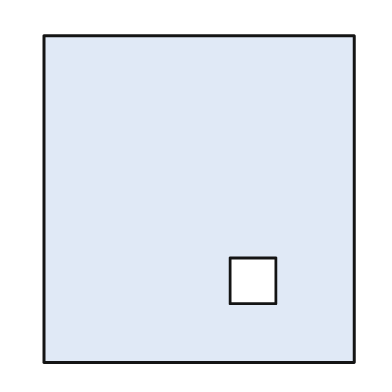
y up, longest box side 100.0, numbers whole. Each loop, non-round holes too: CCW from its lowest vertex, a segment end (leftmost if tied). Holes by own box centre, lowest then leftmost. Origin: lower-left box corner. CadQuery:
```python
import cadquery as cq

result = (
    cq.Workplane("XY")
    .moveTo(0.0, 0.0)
    .lineTo(95.0, 0.0)
    .lineTo(95.0, 100.0)
    .lineTo(0.0, 100.0)
    .close()
    .moveTo(57.0, 18.0)
    .lineTo(71.0, 18.0)
    .lineTo(71.0, 32.0)
    .lineTo(57.0, 32.0)
    .close()
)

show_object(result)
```